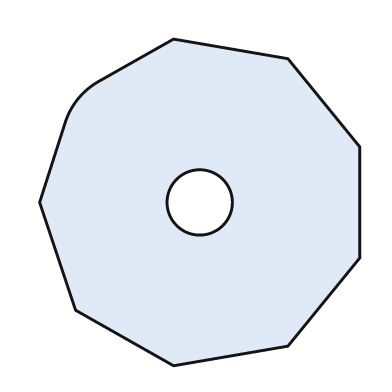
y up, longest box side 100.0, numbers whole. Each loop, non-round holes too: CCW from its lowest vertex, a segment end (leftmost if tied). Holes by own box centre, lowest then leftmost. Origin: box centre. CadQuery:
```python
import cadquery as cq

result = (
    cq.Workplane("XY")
    .moveTo(-8.0, -50.0)
    .lineTo(27.0, -44.0)
    .lineTo(49.0, -17.0)
    .lineTo(49.0, 17.0)
    .lineTo(27.0, 44.0)
    .lineTo(-8.0, 50.0)
    .lineTo(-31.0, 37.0)
    .threePointArc((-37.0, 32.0), (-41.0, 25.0))
    .lineTo(-49.0, 0.0)
    .lineTo(-38.0, -33.0)
    .close()
    .moveTo(0.0, 0.0)
    .circle(10.0)
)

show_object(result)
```